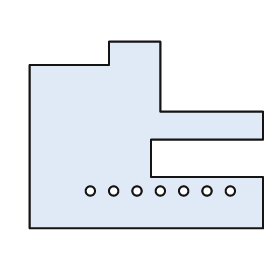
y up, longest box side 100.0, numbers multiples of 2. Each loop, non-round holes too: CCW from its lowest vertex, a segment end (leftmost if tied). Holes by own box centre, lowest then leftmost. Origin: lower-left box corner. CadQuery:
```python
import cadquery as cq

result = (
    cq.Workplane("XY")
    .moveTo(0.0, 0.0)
    .lineTo(100.0, 0.0)
    .lineTo(100.0, 22.0)
    .lineTo(52.0, 22.0)
    .lineTo(52.0, 38.0)
    .lineTo(100.0, 38.0)
    .lineTo(100.0, 50.0)
    .lineTo(56.0, 50.0)
    .lineTo(56.0, 80.0)
    .lineTo(34.0, 80.0)
    .lineTo(34.0, 70.0)
    .lineTo(0.0, 70.0)
    .close()
    .moveTo(26.0, 16.0)
    .circle(2.0)
    .moveTo(36.0, 16.0)
    .circle(2.0)
    .moveTo(46.0, 16.0)
    .circle(2.0)
    .moveTo(56.0, 16.0)
    .circle(2.0)
    .moveTo(66.0, 16.0)
    .circle(2.0)
    .moveTo(76.0, 16.0)
    .circle(2.0)
    .moveTo(86.0, 16.0)
    .circle(2.0)
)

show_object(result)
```